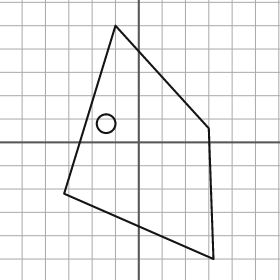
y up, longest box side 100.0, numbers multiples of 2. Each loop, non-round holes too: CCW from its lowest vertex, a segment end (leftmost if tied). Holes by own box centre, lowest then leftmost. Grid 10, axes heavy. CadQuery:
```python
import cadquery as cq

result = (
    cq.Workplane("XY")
    .moveTo(32.0, -50.0)
    .lineTo(30.0, 6.0)
    .lineTo(-10.0, 50.0)
    .lineTo(-32.0, -22.0)
    .close()
    .moveTo(-14.0, 8.0)
    .circle(4.0)
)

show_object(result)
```